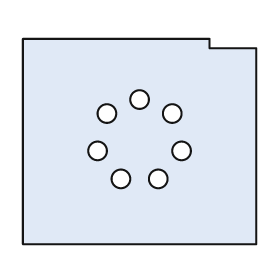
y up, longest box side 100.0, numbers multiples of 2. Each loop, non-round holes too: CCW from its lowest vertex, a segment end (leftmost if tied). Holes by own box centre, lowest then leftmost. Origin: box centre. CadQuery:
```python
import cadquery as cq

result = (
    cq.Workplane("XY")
    .moveTo(-50.0, -44.0)
    .lineTo(50.0, -44.0)
    .lineTo(50.0, 40.0)
    .lineTo(30.0, 40.0)
    .lineTo(30.0, 44.0)
    .lineTo(-50.0, 44.0)
    .close()
    .moveTo(-8.0, -16.0)
    .circle(4.0)
    .moveTo(8.0, -16.0)
    .circle(4.0)
    .moveTo(-18.0, -4.0)
    .circle(4.0)
    .moveTo(18.0, -4.0)
    .circle(4.0)
    .moveTo(-14.0, 12.0)
    .circle(4.0)
    .moveTo(14.0, 12.0)
    .circle(4.0)
    .moveTo(0.0, 18.0)
    .circle(4.0)
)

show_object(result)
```